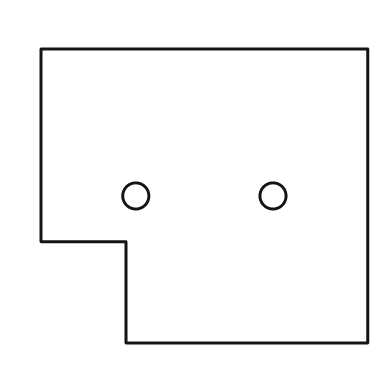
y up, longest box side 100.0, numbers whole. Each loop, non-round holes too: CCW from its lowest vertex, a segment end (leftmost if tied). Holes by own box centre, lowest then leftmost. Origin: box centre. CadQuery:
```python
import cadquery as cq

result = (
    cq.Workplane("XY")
    .moveTo(-24.0, -45.0)
    .lineTo(50.0, -45.0)
    .lineTo(50.0, 45.0)
    .lineTo(-50.0, 45.0)
    .lineTo(-50.0, -14.0)
    .lineTo(-24.0, -14.0)
    .close()
    .moveTo(-21.0, 0.0)
    .circle(4.0)
    .moveTo(21.0, 0.0)
    .circle(4.0)
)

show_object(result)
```